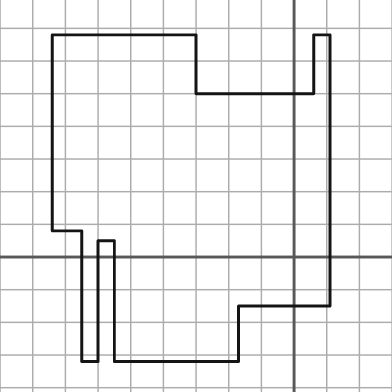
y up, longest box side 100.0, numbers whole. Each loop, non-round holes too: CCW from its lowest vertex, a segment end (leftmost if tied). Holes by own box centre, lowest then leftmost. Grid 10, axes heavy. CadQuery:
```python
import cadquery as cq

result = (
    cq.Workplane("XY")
    .moveTo(-65.0, -32.0)
    .lineTo(-60.0, -32.0)
    .lineTo(-60.0, 5.0)
    .lineTo(-55.0, 5.0)
    .lineTo(-55.0, -32.0)
    .lineTo(-17.0, -32.0)
    .lineTo(-17.0, -15.0)
    .lineTo(11.0, -15.0)
    .lineTo(11.0, 68.0)
    .lineTo(6.0, 68.0)
    .lineTo(6.0, 50.0)
    .lineTo(-30.0, 50.0)
    .lineTo(-30.0, 68.0)
    .lineTo(-74.0, 68.0)
    .lineTo(-74.0, 8.0)
    .lineTo(-65.0, 8.0)
    .close()
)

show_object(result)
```